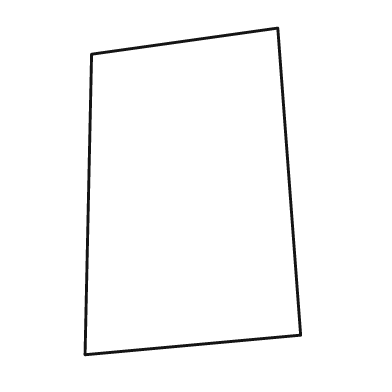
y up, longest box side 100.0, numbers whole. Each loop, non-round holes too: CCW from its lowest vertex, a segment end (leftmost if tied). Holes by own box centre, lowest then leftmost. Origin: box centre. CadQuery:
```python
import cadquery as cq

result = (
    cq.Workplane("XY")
    .moveTo(-33.0, -50.0)
    .lineTo(33.0, -44.0)
    .lineTo(26.0, 50.0)
    .lineTo(-31.0, 42.0)
    .close()
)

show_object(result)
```